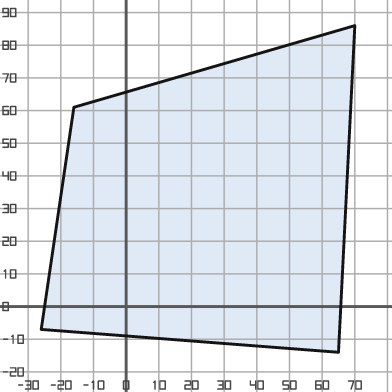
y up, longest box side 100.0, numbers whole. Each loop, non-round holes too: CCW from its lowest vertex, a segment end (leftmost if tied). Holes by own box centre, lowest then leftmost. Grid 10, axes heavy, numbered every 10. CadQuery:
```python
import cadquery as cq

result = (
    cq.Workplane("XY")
    .moveTo(65.0, -14.0)
    .lineTo(70.0, 86.0)
    .lineTo(-16.0, 61.0)
    .lineTo(-26.0, -7.0)
    .close()
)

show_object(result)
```